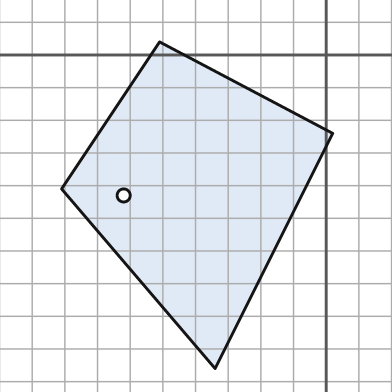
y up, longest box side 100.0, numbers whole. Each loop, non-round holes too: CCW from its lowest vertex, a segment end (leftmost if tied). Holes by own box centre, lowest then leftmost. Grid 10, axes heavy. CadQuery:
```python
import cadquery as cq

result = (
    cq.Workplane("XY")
    .moveTo(-34.0, -96.0)
    .lineTo(2.0, -24.0)
    .lineTo(-51.0, 4.0)
    .lineTo(-81.0, -41.0)
    .close()
    .moveTo(-62.0, -43.0)
    .circle(2.0)
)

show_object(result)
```